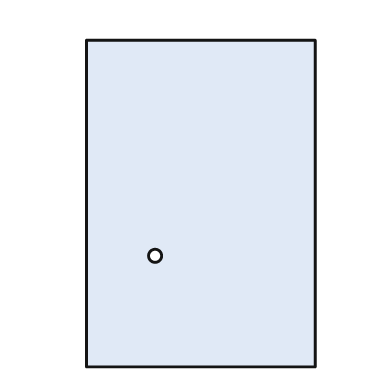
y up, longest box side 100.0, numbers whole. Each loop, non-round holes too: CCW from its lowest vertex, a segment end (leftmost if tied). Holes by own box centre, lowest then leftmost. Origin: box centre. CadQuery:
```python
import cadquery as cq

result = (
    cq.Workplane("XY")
    .moveTo(-35.0, -50.0)
    .lineTo(35.0, -50.0)
    .lineTo(35.0, 50.0)
    .lineTo(-35.0, 50.0)
    .close()
    .moveTo(-14.0, -16.0)
    .circle(2.0)
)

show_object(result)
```